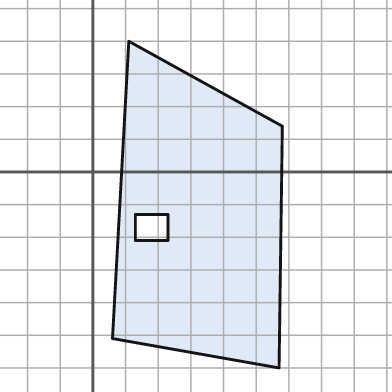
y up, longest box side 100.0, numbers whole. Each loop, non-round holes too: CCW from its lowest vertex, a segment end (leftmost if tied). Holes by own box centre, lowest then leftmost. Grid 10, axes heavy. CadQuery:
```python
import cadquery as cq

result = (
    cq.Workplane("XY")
    .moveTo(57.0, -60.0)
    .lineTo(58.0, 14.0)
    .lineTo(11.0, 40.0)
    .lineTo(6.0, -51.0)
    .close()
    .moveTo(13.0, -21.0)
    .lineTo(23.0, -21.0)
    .lineTo(23.0, -13.0)
    .lineTo(13.0, -13.0)
    .close()
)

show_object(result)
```